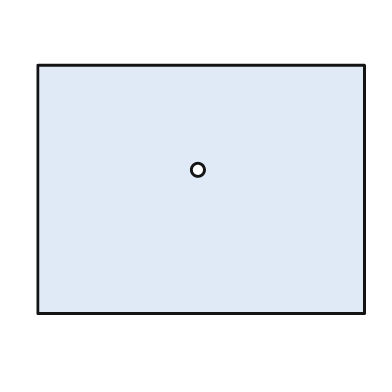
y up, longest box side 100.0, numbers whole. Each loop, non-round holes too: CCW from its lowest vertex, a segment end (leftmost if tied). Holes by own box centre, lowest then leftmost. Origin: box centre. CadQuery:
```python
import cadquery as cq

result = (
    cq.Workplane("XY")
    .moveTo(-50.0, -38.0)
    .lineTo(50.0, -38.0)
    .lineTo(50.0, 38.0)
    .lineTo(-50.0, 38.0)
    .close()
    .moveTo(-1.0, 6.0)
    .circle(2.0)
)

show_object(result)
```